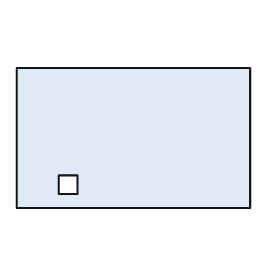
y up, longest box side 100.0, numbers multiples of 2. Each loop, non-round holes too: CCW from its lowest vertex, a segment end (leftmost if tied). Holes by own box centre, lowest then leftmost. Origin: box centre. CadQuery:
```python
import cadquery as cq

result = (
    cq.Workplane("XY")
    .moveTo(-50.0, -30.0)
    .lineTo(50.0, -30.0)
    .lineTo(50.0, 30.0)
    .lineTo(-50.0, 30.0)
    .close()
    .moveTo(-32.0, -24.0)
    .lineTo(-24.0, -24.0)
    .lineTo(-24.0, -16.0)
    .lineTo(-32.0, -16.0)
    .close()
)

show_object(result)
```